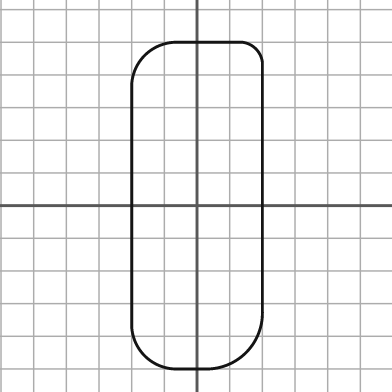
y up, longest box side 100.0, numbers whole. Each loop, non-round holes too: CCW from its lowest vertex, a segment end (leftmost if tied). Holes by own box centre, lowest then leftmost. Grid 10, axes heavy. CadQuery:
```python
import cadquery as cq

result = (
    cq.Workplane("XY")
    .moveTo(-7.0, -50.0)
    .lineTo(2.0, -50.0)
    .threePointArc((15.0, -45.0), (20.0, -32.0))
    .lineTo(20.0, 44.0)
    .threePointArc((18.0, 48.0), (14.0, 50.0))
    .lineTo(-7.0, 50.0)
    .threePointArc((-16.0, 46.0), (-20.0, 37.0))
    .lineTo(-20.0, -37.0)
    .threePointArc((-16.0, -46.0), (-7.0, -50.0))
    .close()
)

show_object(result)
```